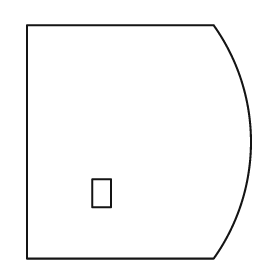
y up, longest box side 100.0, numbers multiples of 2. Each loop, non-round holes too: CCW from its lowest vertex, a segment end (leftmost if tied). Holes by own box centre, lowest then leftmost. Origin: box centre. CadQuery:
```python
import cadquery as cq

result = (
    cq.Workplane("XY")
    .moveTo(-48.0, -50.0)
    .lineTo(32.0, -50.0)
    .threePointArc((48.0, 0.0), (32.0, 50.0))
    .lineTo(-48.0, 50.0)
    .close()
    .moveTo(-20.0, -28.0)
    .lineTo(-12.0, -28.0)
    .lineTo(-12.0, -16.0)
    .lineTo(-20.0, -16.0)
    .close()
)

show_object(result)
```